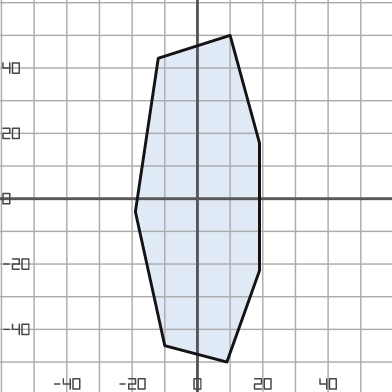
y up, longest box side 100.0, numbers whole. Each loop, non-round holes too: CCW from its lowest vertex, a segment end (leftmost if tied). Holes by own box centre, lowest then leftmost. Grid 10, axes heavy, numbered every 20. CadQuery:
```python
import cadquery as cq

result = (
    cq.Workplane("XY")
    .moveTo(9.0, -50.0)
    .lineTo(19.0, -22.0)
    .lineTo(19.0, 17.0)
    .lineTo(10.0, 50.0)
    .lineTo(-12.0, 43.0)
    .lineTo(-19.0, -4.0)
    .lineTo(-10.0, -45.0)
    .close()
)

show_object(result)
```